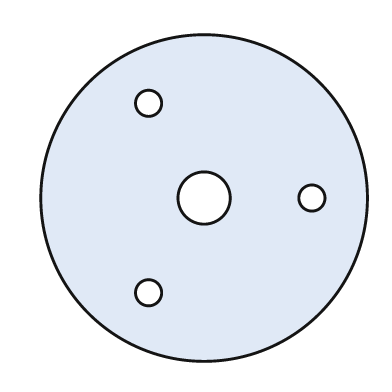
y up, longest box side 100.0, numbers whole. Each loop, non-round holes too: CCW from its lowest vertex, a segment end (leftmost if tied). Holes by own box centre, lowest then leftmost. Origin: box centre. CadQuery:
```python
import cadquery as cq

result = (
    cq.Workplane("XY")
    .moveTo(0.0, 0.0)
    .circle(50.0)
    .moveTo(-17.0, -29.0)
    .circle(4.0)
    .moveTo(0.0, 0.0)
    .circle(8.0)
    .moveTo(33.0, 0.0)
    .circle(4.0)
    .moveTo(-17.0, 29.0)
    .circle(4.0)
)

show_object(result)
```